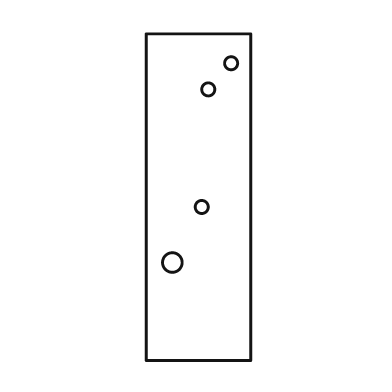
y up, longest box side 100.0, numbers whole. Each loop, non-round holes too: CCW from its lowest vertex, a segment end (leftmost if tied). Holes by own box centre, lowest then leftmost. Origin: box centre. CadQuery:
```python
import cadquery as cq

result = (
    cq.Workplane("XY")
    .moveTo(-16.0, -50.0)
    .lineTo(16.0, -50.0)
    .lineTo(16.0, 50.0)
    .lineTo(-16.0, 50.0)
    .close()
    .moveTo(-8.0, -20.0)
    .circle(3.0)
    .moveTo(1.0, -3.0)
    .circle(2.0)
    .moveTo(3.0, 33.0)
    .circle(2.0)
    .moveTo(10.0, 41.0)
    .circle(2.0)
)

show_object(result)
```